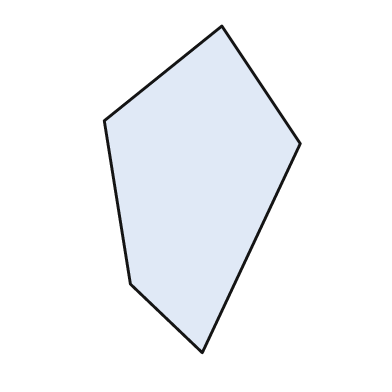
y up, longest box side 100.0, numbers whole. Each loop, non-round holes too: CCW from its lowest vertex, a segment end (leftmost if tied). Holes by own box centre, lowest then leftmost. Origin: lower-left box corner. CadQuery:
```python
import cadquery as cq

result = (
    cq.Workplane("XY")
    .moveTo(30.0, 0.0)
    .lineTo(60.0, 64.0)
    .lineTo(36.0, 100.0)
    .lineTo(0.0, 71.0)
    .lineTo(8.0, 21.0)
    .close()
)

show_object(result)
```